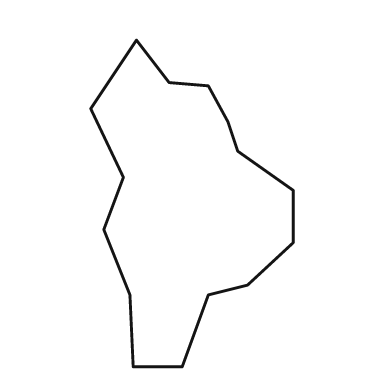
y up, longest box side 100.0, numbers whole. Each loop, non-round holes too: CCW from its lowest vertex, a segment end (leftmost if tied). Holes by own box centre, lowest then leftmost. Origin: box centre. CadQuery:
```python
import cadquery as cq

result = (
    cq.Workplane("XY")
    .moveTo(-18.0, -50.0)
    .lineTo(-3.0, -50.0)
    .lineTo(5.0, -28.0)
    .lineTo(17.0, -25.0)
    .lineTo(31.0, -12.0)
    .lineTo(31.0, 4.0)
    .lineTo(14.0, 16.0)
    .lineTo(11.0, 25.0)
    .lineTo(5.0, 36.0)
    .lineTo(-7.0, 37.0)
    .lineTo(-17.0, 50.0)
    .lineTo(-31.0, 29.0)
    .lineTo(-21.0, 8.0)
    .lineTo(-27.0, -8.0)
    .lineTo(-19.0, -28.0)
    .close()
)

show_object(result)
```